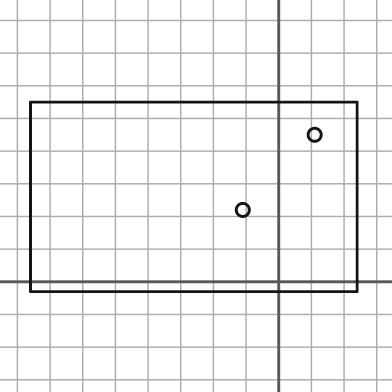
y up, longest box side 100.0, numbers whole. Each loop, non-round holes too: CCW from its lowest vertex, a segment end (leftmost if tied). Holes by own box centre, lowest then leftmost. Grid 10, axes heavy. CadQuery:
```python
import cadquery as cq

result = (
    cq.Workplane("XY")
    .moveTo(-76.0, -3.0)
    .lineTo(24.0, -3.0)
    .lineTo(24.0, 55.0)
    .lineTo(-76.0, 55.0)
    .close()
    .moveTo(-11.0, 22.0)
    .circle(2.0)
    .moveTo(11.0, 45.0)
    .circle(2.0)
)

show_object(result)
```